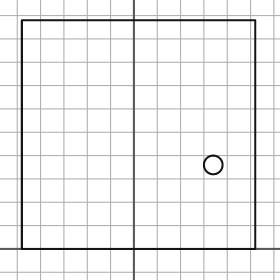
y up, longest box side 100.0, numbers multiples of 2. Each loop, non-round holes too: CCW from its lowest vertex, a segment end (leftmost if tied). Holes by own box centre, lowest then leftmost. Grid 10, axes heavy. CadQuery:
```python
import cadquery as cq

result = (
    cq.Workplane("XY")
    .moveTo(-48.0, 0.0)
    .lineTo(52.0, 0.0)
    .lineTo(52.0, 98.0)
    .lineTo(-48.0, 98.0)
    .close()
    .moveTo(34.0, 36.0)
    .circle(4.0)
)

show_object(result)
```